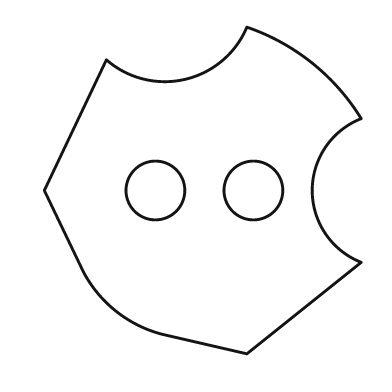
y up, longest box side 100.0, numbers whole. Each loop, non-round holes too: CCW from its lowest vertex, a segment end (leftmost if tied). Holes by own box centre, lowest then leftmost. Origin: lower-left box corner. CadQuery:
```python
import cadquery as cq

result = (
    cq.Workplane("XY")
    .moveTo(62.0, 0.0)
    .lineTo(97.0, 28.0)
    .threePointArc((82.0, 50.0), (97.0, 72.0))
    .threePointArc((82.0, 89.0), (62.0, 100.0))
    .threePointArc((43.0, 84.0), (19.0, 90.0))
    .lineTo(0.0, 50.0)
    .lineTo(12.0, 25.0)
    .threePointArc((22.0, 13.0), (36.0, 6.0))
    .close()
    .moveTo(34.0, 50.0)
    .circle(9.0)
    .moveTo(64.0, 50.0)
    .circle(9.0)
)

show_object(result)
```